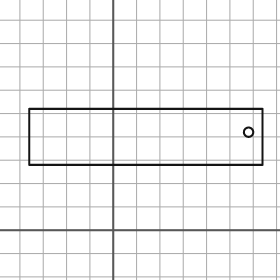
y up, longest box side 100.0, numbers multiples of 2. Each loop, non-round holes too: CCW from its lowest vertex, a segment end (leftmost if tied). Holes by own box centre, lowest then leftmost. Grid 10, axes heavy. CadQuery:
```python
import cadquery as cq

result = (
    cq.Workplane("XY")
    .moveTo(-36.0, 28.0)
    .lineTo(64.0, 28.0)
    .lineTo(64.0, 52.0)
    .lineTo(-36.0, 52.0)
    .close()
    .moveTo(58.0, 42.0)
    .circle(2.0)
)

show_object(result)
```